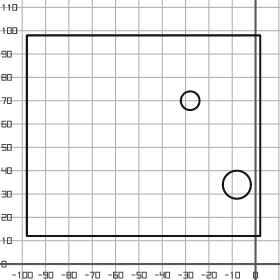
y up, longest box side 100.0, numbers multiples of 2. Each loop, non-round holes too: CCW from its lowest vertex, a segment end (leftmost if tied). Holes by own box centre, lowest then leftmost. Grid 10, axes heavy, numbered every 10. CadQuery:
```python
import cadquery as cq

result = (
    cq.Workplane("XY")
    .moveTo(-98.0, 12.0)
    .lineTo(2.0, 12.0)
    .lineTo(2.0, 98.0)
    .lineTo(-98.0, 98.0)
    .close()
    .moveTo(-8.0, 34.0)
    .circle(6.0)
    .moveTo(-28.0, 70.0)
    .circle(4.0)
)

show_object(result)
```